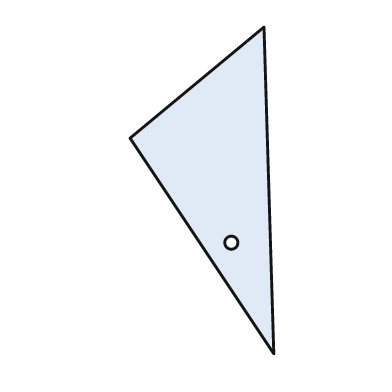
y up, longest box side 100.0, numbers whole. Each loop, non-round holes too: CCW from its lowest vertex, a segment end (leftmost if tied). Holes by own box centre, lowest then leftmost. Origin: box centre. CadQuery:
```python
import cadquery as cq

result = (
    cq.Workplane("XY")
    .moveTo(22.0, -50.0)
    .lineTo(19.0, 50.0)
    .lineTo(-22.0, 16.0)
    .close()
    .moveTo(9.0, -16.0)
    .circle(2.0)
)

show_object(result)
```